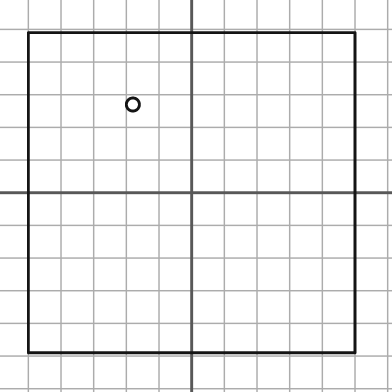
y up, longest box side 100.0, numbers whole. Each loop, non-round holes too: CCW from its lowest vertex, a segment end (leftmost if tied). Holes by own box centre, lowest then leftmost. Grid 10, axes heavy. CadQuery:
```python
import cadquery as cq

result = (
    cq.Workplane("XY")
    .moveTo(-50.0, -49.0)
    .lineTo(50.0, -49.0)
    .lineTo(50.0, 49.0)
    .lineTo(-50.0, 49.0)
    .close()
    .moveTo(-18.0, 27.0)
    .circle(2.0)
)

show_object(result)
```